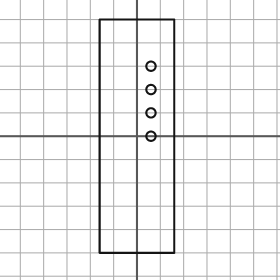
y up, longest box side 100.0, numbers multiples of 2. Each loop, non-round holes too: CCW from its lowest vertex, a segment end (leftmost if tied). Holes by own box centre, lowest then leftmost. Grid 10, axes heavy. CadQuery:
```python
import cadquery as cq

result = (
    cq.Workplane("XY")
    .moveTo(-16.0, -50.0)
    .lineTo(16.0, -50.0)
    .lineTo(16.0, 50.0)
    .lineTo(-16.0, 50.0)
    .close()
    .moveTo(6.0, 0.0)
    .circle(2.0)
    .moveTo(6.0, 10.0)
    .circle(2.0)
    .moveTo(6.0, 20.0)
    .circle(2.0)
    .moveTo(6.0, 30.0)
    .circle(2.0)
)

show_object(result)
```